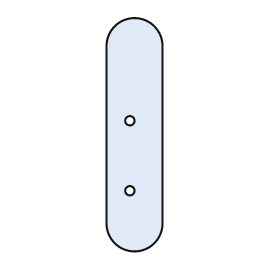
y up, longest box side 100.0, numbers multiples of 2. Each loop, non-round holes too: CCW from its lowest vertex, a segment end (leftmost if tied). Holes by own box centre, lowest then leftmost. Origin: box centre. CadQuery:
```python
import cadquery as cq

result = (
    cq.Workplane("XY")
    .moveTo(-12.0, -38.0)
    .threePointArc((0.0, -50.0), (12.0, -38.0))
    .lineTo(12.0, 38.0)
    .threePointArc((0.0, 50.0), (-12.0, 38.0))
    .close()
    .moveTo(-2.0, -24.0)
    .circle(2.0)
    .moveTo(-2.0, 6.0)
    .circle(2.0)
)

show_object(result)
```